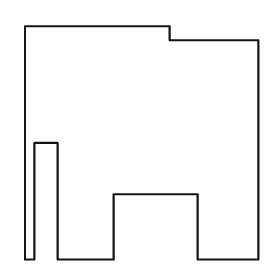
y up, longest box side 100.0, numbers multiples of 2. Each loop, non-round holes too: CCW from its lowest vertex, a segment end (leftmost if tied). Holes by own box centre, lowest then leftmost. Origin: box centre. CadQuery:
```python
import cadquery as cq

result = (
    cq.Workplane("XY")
    .moveTo(-50.0, -50.0)
    .lineTo(-46.0, -50.0)
    .lineTo(-46.0, 0.0)
    .lineTo(-36.0, 0.0)
    .lineTo(-36.0, -50.0)
    .lineTo(-12.0, -50.0)
    .lineTo(-12.0, -22.0)
    .lineTo(24.0, -22.0)
    .lineTo(24.0, -50.0)
    .lineTo(50.0, -50.0)
    .lineTo(50.0, 44.0)
    .lineTo(12.0, 44.0)
    .lineTo(12.0, 50.0)
    .lineTo(-50.0, 50.0)
    .close()
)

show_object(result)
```